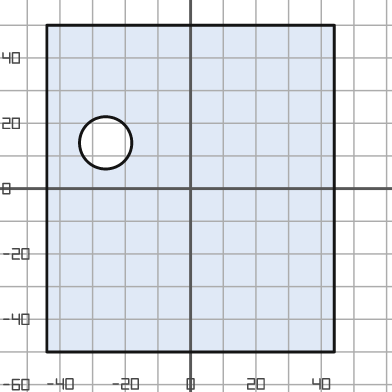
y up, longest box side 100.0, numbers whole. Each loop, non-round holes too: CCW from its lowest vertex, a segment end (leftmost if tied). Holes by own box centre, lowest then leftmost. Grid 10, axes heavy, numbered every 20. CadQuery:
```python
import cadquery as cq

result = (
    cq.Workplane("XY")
    .moveTo(-44.0, -50.0)
    .lineTo(44.0, -50.0)
    .lineTo(44.0, 50.0)
    .lineTo(-44.0, 50.0)
    .close()
    .moveTo(-26.0, 14.0)
    .circle(8.0)
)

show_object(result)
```